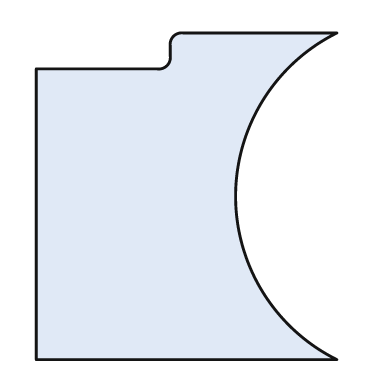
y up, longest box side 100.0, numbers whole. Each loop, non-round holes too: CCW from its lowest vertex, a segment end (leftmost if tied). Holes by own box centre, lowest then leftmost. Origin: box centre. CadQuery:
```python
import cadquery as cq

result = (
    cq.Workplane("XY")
    .moveTo(-46.0, -50.0)
    .lineTo(46.0, -50.0)
    .threePointArc((15.0, 0.0), (46.0, 50.0))
    .lineTo(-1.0, 50.0)
    .threePointArc((-4.0, 49.0), (-5.0, 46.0))
    .lineTo(-5.0, 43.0)
    .threePointArc((-6.0, 40.0), (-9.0, 39.0))
    .lineTo(-46.0, 39.0)
    .close()
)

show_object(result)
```